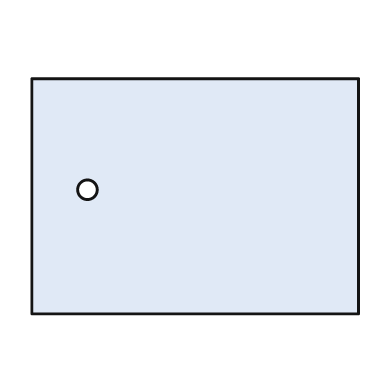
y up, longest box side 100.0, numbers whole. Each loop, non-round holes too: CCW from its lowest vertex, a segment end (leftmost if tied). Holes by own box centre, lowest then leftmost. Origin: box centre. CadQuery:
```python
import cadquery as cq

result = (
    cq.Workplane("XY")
    .moveTo(-50.0, -36.0)
    .lineTo(50.0, -36.0)
    .lineTo(50.0, 36.0)
    .lineTo(-50.0, 36.0)
    .close()
    .moveTo(-33.0, 2.0)
    .circle(3.0)
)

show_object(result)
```